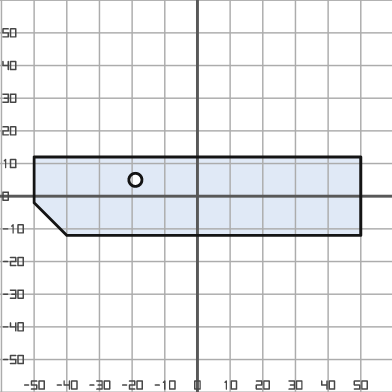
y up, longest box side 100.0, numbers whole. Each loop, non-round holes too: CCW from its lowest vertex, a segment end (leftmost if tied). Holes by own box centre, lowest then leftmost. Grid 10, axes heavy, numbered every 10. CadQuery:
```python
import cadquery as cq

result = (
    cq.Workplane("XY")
    .moveTo(-40.0, -12.0)
    .lineTo(50.0, -12.0)
    .lineTo(50.0, 12.0)
    .lineTo(-50.0, 12.0)
    .lineTo(-50.0, -2.0)
    .close()
    .moveTo(-19.0, 5.0)
    .circle(2.0)
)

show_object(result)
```